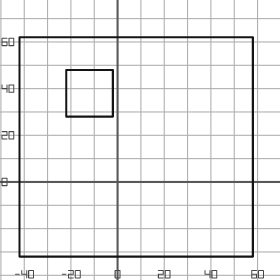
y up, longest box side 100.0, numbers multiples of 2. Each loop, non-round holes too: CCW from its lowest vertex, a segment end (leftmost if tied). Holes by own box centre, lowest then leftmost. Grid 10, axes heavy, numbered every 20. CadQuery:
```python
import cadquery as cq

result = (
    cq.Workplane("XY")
    .moveTo(-42.0, -32.0)
    .lineTo(58.0, -32.0)
    .lineTo(58.0, 62.0)
    .lineTo(-42.0, 62.0)
    .close()
    .moveTo(-22.0, 28.0)
    .lineTo(-2.0, 28.0)
    .lineTo(-2.0, 48.0)
    .lineTo(-22.0, 48.0)
    .close()
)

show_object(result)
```